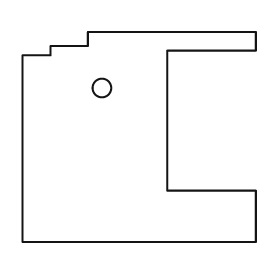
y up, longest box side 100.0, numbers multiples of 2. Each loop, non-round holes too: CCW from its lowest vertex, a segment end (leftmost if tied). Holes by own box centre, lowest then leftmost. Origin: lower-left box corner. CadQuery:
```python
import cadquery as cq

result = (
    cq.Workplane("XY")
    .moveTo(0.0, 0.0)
    .lineTo(100.0, 0.0)
    .lineTo(100.0, 22.0)
    .lineTo(62.0, 22.0)
    .lineTo(62.0, 82.0)
    .lineTo(100.0, 82.0)
    .lineTo(100.0, 90.0)
    .lineTo(28.0, 90.0)
    .lineTo(28.0, 84.0)
    .lineTo(12.0, 84.0)
    .lineTo(12.0, 80.0)
    .lineTo(0.0, 80.0)
    .close()
    .moveTo(34.0, 66.0)
    .circle(4.0)
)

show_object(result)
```